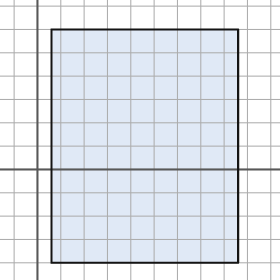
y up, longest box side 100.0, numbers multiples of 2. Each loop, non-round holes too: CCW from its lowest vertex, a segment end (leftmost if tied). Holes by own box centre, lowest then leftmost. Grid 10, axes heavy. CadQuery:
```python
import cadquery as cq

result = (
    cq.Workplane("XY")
    .moveTo(6.0, -40.0)
    .lineTo(86.0, -40.0)
    .lineTo(86.0, 60.0)
    .lineTo(6.0, 60.0)
    .close()
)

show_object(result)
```